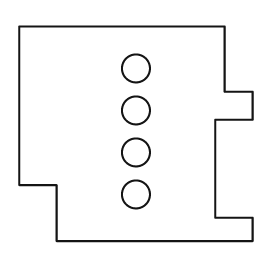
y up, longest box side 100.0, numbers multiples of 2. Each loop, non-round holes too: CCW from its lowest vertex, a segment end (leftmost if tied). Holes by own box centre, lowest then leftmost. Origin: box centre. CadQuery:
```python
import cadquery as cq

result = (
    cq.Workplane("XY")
    .moveTo(-34.0, -46.0)
    .lineTo(50.0, -46.0)
    .lineTo(50.0, -36.0)
    .lineTo(34.0, -36.0)
    .lineTo(34.0, 6.0)
    .lineTo(50.0, 6.0)
    .lineTo(50.0, 18.0)
    .lineTo(38.0, 18.0)
    .lineTo(38.0, 46.0)
    .lineTo(-50.0, 46.0)
    .lineTo(-50.0, -22.0)
    .lineTo(-34.0, -22.0)
    .close()
    .moveTo(0.0, -26.0)
    .circle(6.0)
    .moveTo(0.0, -8.0)
    .circle(6.0)
    .moveTo(0.0, 10.0)
    .circle(6.0)
    .moveTo(0.0, 28.0)
    .circle(6.0)
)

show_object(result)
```